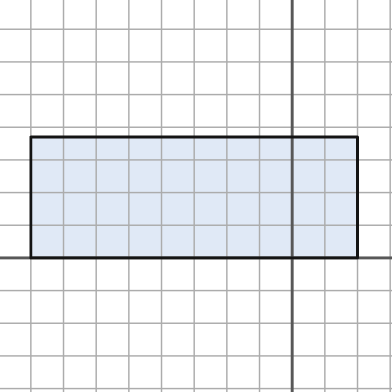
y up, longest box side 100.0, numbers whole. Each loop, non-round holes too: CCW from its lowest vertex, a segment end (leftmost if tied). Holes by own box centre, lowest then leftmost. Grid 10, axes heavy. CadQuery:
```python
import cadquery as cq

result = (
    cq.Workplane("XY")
    .moveTo(-80.0, 0.0)
    .lineTo(20.0, 0.0)
    .lineTo(20.0, 37.0)
    .lineTo(-80.0, 37.0)
    .close()
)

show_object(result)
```